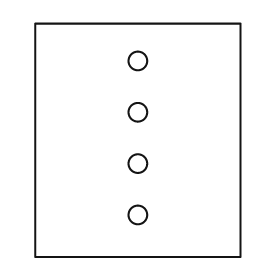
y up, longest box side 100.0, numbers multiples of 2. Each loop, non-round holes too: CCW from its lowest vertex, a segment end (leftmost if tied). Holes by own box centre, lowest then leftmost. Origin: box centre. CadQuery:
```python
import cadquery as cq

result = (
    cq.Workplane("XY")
    .moveTo(-44.0, -50.0)
    .lineTo(44.0, -50.0)
    .lineTo(44.0, 50.0)
    .lineTo(-44.0, 50.0)
    .close()
    .moveTo(0.0, -32.0)
    .circle(4.0)
    .moveTo(0.0, -10.0)
    .circle(4.0)
    .moveTo(0.0, 12.0)
    .circle(4.0)
    .moveTo(0.0, 34.0)
    .circle(4.0)
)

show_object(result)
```